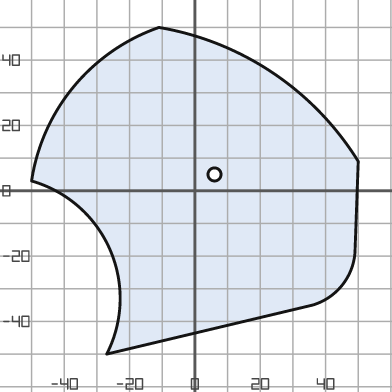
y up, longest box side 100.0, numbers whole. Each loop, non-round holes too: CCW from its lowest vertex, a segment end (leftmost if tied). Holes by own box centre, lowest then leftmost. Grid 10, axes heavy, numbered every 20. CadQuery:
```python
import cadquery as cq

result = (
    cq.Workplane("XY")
    .moveTo(-27.0, -50.0)
    .lineTo(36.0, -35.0)
    .threePointArc((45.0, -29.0), (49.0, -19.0))
    .lineTo(50.0, 9.0)
    .threePointArc((24.0, 36.0), (-11.0, 50.0))
    .threePointArc((-37.0, 32.0), (-50.0, 3.0))
    .threePointArc((-26.0, -18.0), (-27.0, -50.0))
    .close()
    .moveTo(6.0, 5.0)
    .circle(2.0)
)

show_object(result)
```